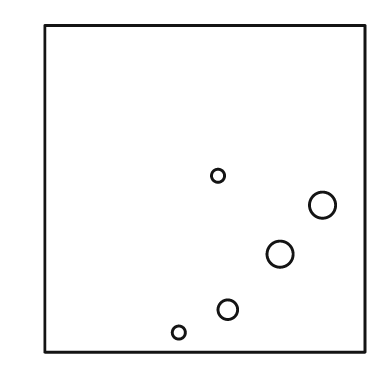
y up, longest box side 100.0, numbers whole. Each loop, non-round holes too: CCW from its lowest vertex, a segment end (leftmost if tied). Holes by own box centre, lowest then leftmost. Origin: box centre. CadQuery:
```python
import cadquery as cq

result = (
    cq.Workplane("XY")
    .moveTo(-49.0, -50.0)
    .lineTo(49.0, -50.0)
    .lineTo(49.0, 50.0)
    .lineTo(-49.0, 50.0)
    .close()
    .moveTo(-8.0, -44.0)
    .circle(2.0)
    .moveTo(7.0, -37.0)
    .circle(3.0)
    .moveTo(23.0, -20.0)
    .circle(4.0)
    .moveTo(36.0, -5.0)
    .circle(4.0)
    .moveTo(4.0, 4.0)
    .circle(2.0)
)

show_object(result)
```